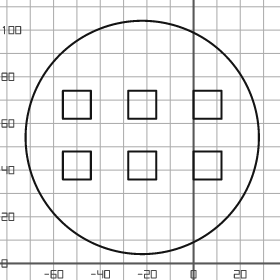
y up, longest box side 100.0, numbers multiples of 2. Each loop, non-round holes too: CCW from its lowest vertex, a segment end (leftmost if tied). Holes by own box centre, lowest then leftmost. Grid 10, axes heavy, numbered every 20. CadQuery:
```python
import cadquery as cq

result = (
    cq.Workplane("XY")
    .moveTo(-22.0, 54.0)
    .circle(50.0)
    .moveTo(-56.0, 36.0)
    .lineTo(-44.0, 36.0)
    .lineTo(-44.0, 48.0)
    .lineTo(-56.0, 48.0)
    .close()
    .moveTo(-28.0, 36.0)
    .lineTo(-16.0, 36.0)
    .lineTo(-16.0, 48.0)
    .lineTo(-28.0, 48.0)
    .close()
    .moveTo(0.0, 36.0)
    .lineTo(12.0, 36.0)
    .lineTo(12.0, 48.0)
    .lineTo(0.0, 48.0)
    .close()
    .moveTo(-56.0, 62.0)
    .lineTo(-44.0, 62.0)
    .lineTo(-44.0, 74.0)
    .lineTo(-56.0, 74.0)
    .close()
    .moveTo(-28.0, 62.0)
    .lineTo(-16.0, 62.0)
    .lineTo(-16.0, 74.0)
    .lineTo(-28.0, 74.0)
    .close()
    .moveTo(0.0, 62.0)
    .lineTo(12.0, 62.0)
    .lineTo(12.0, 74.0)
    .lineTo(0.0, 74.0)
    .close()
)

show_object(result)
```